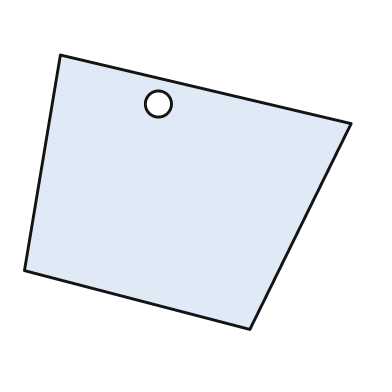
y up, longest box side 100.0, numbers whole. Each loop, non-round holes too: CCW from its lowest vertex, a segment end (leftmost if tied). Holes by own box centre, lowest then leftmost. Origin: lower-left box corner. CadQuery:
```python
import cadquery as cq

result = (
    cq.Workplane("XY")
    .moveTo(69.0, 0.0)
    .lineTo(100.0, 63.0)
    .lineTo(11.0, 84.0)
    .lineTo(0.0, 18.0)
    .close()
    .moveTo(41.0, 69.0)
    .circle(4.0)
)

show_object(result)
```